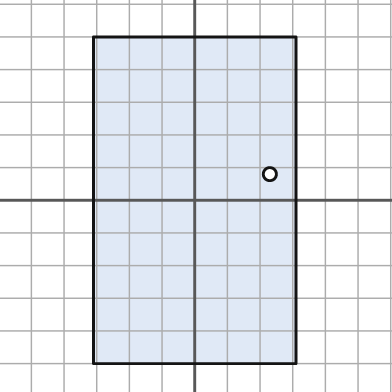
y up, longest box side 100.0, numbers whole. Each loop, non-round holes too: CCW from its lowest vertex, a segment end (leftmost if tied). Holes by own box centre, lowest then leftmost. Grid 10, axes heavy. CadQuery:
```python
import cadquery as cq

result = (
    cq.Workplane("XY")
    .moveTo(-31.0, -50.0)
    .lineTo(31.0, -50.0)
    .lineTo(31.0, 50.0)
    .lineTo(-31.0, 50.0)
    .close()
    .moveTo(23.0, 8.0)
    .circle(2.0)
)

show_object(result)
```